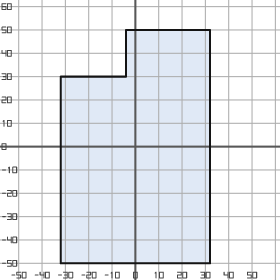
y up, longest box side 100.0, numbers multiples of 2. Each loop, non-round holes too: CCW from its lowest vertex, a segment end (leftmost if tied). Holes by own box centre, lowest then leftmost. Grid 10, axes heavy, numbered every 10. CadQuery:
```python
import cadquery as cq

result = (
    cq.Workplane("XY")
    .moveTo(-32.0, -50.0)
    .lineTo(32.0, -50.0)
    .lineTo(32.0, 50.0)
    .lineTo(-4.0, 50.0)
    .lineTo(-4.0, 30.0)
    .lineTo(-32.0, 30.0)
    .close()
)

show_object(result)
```